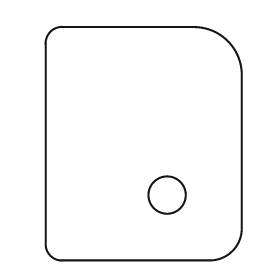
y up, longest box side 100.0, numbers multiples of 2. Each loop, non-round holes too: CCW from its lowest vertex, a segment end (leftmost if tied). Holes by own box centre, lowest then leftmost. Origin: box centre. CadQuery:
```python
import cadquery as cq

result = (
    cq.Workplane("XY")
    .moveTo(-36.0, -50.0)
    .lineTo(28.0, -50.0)
    .threePointArc((38.0, -46.0), (42.0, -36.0))
    .lineTo(42.0, 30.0)
    .threePointArc((36.0, 44.0), (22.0, 50.0))
    .lineTo(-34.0, 50.0)
    .threePointArc((-40.0, 48.0), (-42.0, 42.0))
    .lineTo(-42.0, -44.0)
    .threePointArc((-40.0, -48.0), (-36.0, -50.0))
    .close()
    .moveTo(10.0, -22.0)
    .circle(8.0)
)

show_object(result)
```